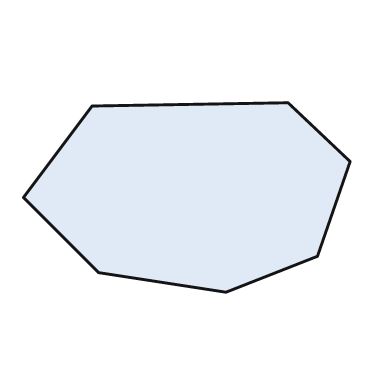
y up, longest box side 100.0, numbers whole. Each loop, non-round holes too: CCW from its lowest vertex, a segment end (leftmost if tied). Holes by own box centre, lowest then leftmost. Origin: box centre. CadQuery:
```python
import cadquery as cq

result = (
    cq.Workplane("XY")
    .moveTo(12.0, -29.0)
    .lineTo(40.0, -18.0)
    .lineTo(50.0, 11.0)
    .lineTo(31.0, 29.0)
    .lineTo(-29.0, 28.0)
    .lineTo(-50.0, 0.0)
    .lineTo(-27.0, -23.0)
    .close()
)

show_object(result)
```